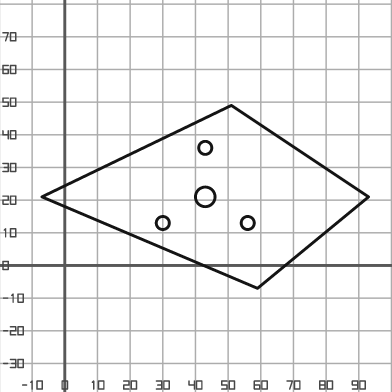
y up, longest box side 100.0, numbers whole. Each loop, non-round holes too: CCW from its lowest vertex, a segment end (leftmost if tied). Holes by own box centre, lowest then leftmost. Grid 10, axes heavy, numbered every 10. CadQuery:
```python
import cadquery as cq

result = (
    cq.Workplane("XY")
    .moveTo(59.0, -7.0)
    .lineTo(93.0, 21.0)
    .lineTo(51.0, 49.0)
    .lineTo(-7.0, 21.0)
    .close()
    .moveTo(30.0, 13.0)
    .circle(2.0)
    .moveTo(56.0, 13.0)
    .circle(2.0)
    .moveTo(43.0, 21.0)
    .circle(3.0)
    .moveTo(43.0, 36.0)
    .circle(2.0)
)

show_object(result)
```